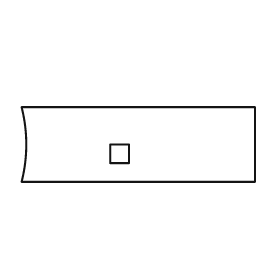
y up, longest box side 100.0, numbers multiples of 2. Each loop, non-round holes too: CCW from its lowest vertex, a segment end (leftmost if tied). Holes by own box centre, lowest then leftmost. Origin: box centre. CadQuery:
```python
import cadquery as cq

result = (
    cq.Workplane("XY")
    .moveTo(-50.0, -16.0)
    .lineTo(50.0, -16.0)
    .lineTo(50.0, 16.0)
    .lineTo(-50.0, 16.0)
    .threePointArc((-48.0, 0.0), (-50.0, -16.0))
    .close()
    .moveTo(-12.0, -8.0)
    .lineTo(-4.0, -8.0)
    .lineTo(-4.0, 0.0)
    .lineTo(-12.0, 0.0)
    .close()
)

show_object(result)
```